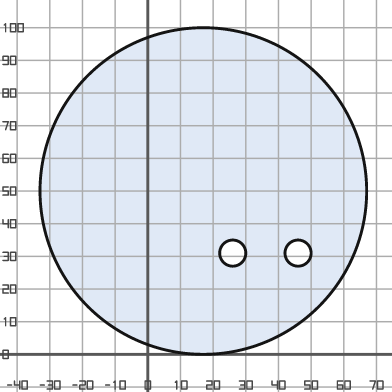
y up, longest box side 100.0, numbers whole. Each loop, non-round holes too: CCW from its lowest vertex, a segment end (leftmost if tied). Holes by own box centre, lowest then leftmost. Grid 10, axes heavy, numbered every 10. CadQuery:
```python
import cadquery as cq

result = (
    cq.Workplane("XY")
    .moveTo(17.0, 50.0)
    .circle(50.0)
    .moveTo(26.0, 31.0)
    .circle(4.0)
    .moveTo(46.0, 31.0)
    .circle(4.0)
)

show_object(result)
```